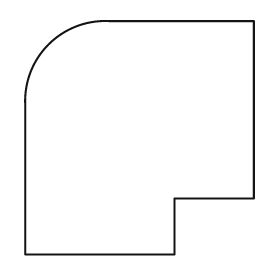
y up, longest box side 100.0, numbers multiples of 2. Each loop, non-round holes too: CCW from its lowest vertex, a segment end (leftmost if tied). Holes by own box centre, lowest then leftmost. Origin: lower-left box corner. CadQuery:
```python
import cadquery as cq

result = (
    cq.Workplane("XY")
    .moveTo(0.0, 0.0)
    .lineTo(64.0, 0.0)
    .lineTo(64.0, 24.0)
    .lineTo(98.0, 24.0)
    .lineTo(98.0, 100.0)
    .lineTo(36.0, 100.0)
    .threePointArc((10.0, 90.0), (0.0, 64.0))
    .close()
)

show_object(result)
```